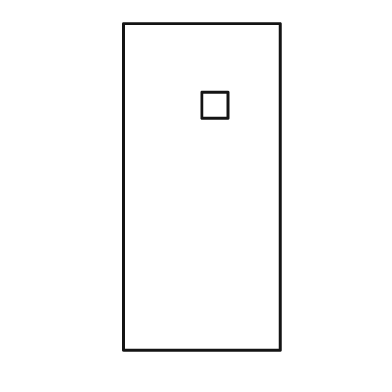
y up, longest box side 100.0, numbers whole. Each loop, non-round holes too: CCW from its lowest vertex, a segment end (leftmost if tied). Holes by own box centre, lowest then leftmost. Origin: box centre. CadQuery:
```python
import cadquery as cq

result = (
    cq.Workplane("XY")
    .moveTo(-24.0, -50.0)
    .lineTo(24.0, -50.0)
    .lineTo(24.0, 50.0)
    .lineTo(-24.0, 50.0)
    .close()
    .moveTo(0.0, 21.0)
    .lineTo(8.0, 21.0)
    .lineTo(8.0, 29.0)
    .lineTo(0.0, 29.0)
    .close()
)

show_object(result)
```